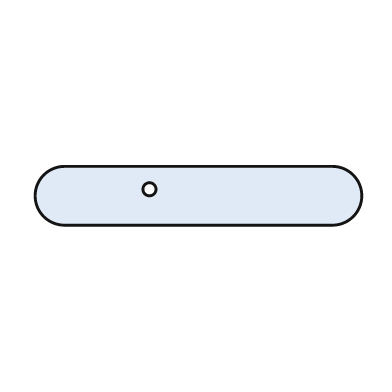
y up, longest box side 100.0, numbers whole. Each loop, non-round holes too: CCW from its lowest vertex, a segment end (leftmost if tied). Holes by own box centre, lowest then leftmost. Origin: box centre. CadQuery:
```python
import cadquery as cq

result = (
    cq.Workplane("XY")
    .moveTo(-41.0, -9.0)
    .lineTo(41.0, -9.0)
    .threePointArc((50.0, 0.0), (41.0, 9.0))
    .lineTo(-41.0, 9.0)
    .threePointArc((-50.0, 0.0), (-41.0, -9.0))
    .close()
    .moveTo(-15.0, 2.0)
    .circle(2.0)
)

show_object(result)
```